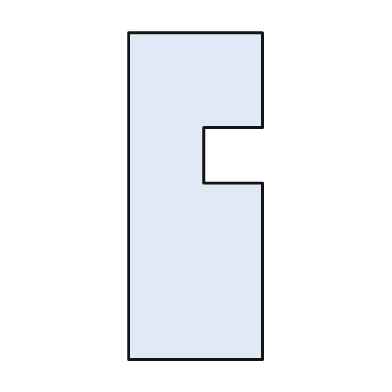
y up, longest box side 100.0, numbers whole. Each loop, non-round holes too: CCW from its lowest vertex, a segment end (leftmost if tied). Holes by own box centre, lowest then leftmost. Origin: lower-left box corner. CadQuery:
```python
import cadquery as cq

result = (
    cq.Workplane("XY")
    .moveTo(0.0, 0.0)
    .lineTo(41.0, 0.0)
    .lineTo(41.0, 54.0)
    .lineTo(23.0, 54.0)
    .lineTo(23.0, 71.0)
    .lineTo(41.0, 71.0)
    .lineTo(41.0, 100.0)
    .lineTo(0.0, 100.0)
    .close()
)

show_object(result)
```